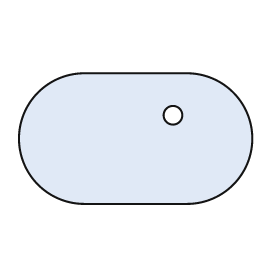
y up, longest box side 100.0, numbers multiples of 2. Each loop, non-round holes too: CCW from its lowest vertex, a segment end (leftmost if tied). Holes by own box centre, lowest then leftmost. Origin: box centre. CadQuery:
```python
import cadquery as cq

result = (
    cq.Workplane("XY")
    .moveTo(-22.0, -28.0)
    .lineTo(22.0, -28.0)
    .threePointArc((50.0, 0.0), (22.0, 28.0))
    .lineTo(-22.0, 28.0)
    .threePointArc((-50.0, 0.0), (-22.0, -28.0))
    .close()
    .moveTo(16.0, 10.0)
    .circle(4.0)
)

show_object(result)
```